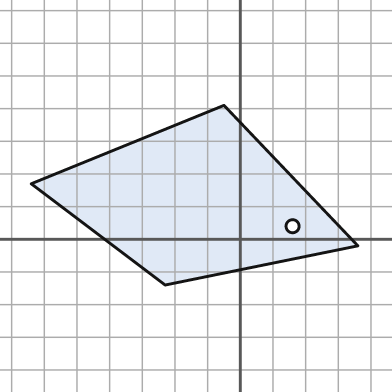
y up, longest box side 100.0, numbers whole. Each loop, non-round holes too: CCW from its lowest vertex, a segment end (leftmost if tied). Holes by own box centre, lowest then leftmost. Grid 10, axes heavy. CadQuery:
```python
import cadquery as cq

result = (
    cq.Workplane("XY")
    .moveTo(-23.0, -14.0)
    .lineTo(36.0, -2.0)
    .lineTo(-5.0, 41.0)
    .lineTo(-64.0, 17.0)
    .close()
    .moveTo(16.0, 4.0)
    .circle(2.0)
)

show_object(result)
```